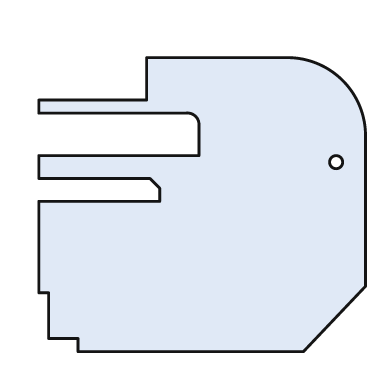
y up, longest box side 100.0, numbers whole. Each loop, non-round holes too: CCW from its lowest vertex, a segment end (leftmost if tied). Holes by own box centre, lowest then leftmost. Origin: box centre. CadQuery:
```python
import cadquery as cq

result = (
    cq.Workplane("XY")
    .moveTo(-38.0, -45.0)
    .lineTo(31.0, -45.0)
    .lineTo(50.0, -25.0)
    .lineTo(50.0, 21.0)
    .threePointArc((43.0, 38.0), (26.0, 45.0))
    .lineTo(-17.0, 45.0)
    .lineTo(-17.0, 32.0)
    .lineTo(-50.0, 32.0)
    .lineTo(-50.0, 28.0)
    .lineTo(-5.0, 28.0)
    .threePointArc((-2.0, 27.0), (-1.0, 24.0))
    .lineTo(-1.0, 15.0)
    .lineTo(-50.0, 15.0)
    .lineTo(-50.0, 8.0)
    .lineTo(-16.0, 8.0)
    .lineTo(-13.0, 5.0)
    .lineTo(-13.0, 1.0)
    .lineTo(-50.0, 1.0)
    .lineTo(-50.0, -27.0)
    .lineTo(-47.0, -27.0)
    .lineTo(-47.0, -41.0)
    .lineTo(-38.0, -41.0)
    .close()
    .moveTo(41.0, 13.0)
    .circle(2.0)
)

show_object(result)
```